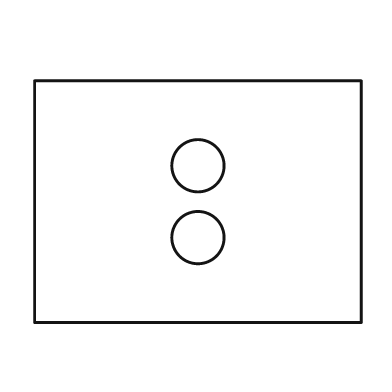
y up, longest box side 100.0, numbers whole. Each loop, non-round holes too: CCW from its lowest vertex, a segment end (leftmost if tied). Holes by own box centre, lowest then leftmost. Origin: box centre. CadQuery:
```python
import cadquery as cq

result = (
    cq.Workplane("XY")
    .moveTo(-50.0, -37.0)
    .lineTo(50.0, -37.0)
    .lineTo(50.0, 37.0)
    .lineTo(-50.0, 37.0)
    .close()
    .moveTo(0.0, -11.0)
    .circle(8.0)
    .moveTo(0.0, 11.0)
    .circle(8.0)
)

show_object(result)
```